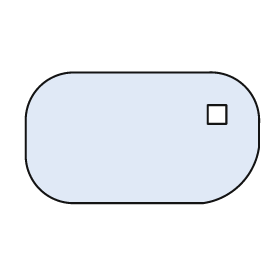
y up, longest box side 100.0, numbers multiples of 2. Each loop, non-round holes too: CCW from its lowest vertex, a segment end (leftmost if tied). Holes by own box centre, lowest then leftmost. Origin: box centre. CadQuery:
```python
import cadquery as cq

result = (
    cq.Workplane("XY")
    .moveTo(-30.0, -28.0)
    .lineTo(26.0, -28.0)
    .threePointArc((42.0, -20.0), (50.0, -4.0))
    .lineTo(50.0, 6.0)
    .threePointArc((44.0, 22.0), (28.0, 28.0))
    .lineTo(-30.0, 28.0)
    .threePointArc((-44.0, 22.0), (-50.0, 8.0))
    .lineTo(-50.0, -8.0)
    .threePointArc((-44.0, -22.0), (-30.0, -28.0))
    .close()
    .moveTo(28.0, 6.0)
    .lineTo(36.0, 6.0)
    .lineTo(36.0, 14.0)
    .lineTo(28.0, 14.0)
    .close()
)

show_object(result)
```